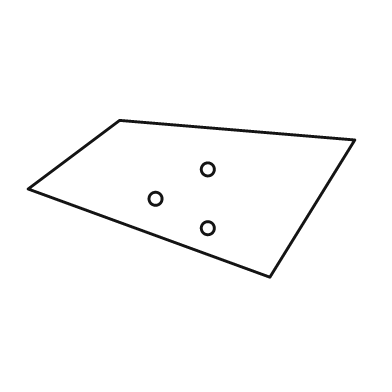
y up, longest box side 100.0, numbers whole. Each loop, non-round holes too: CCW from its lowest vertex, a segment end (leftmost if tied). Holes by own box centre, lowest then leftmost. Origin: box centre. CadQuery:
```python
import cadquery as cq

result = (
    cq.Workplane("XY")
    .moveTo(24.0, -24.0)
    .lineTo(50.0, 18.0)
    .lineTo(-22.0, 24.0)
    .lineTo(-50.0, 3.0)
    .close()
    .moveTo(5.0, -9.0)
    .circle(2.0)
    .moveTo(-11.0, 0.0)
    .circle(2.0)
    .moveTo(5.0, 9.0)
    .circle(2.0)
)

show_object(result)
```